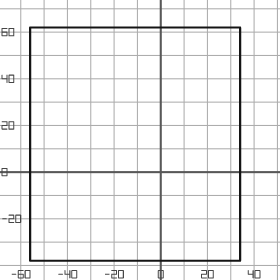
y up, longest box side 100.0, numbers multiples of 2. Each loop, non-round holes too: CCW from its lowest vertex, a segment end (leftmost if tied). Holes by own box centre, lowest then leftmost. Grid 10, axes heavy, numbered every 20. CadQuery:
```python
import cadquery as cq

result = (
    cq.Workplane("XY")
    .moveTo(-56.0, -38.0)
    .lineTo(34.0, -38.0)
    .lineTo(34.0, 62.0)
    .lineTo(-56.0, 62.0)
    .close()
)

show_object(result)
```